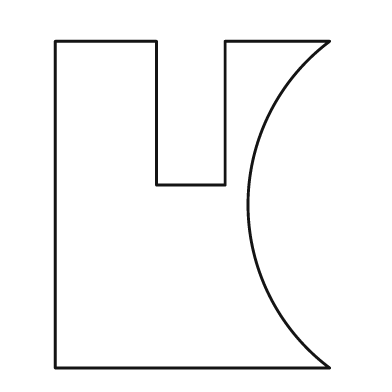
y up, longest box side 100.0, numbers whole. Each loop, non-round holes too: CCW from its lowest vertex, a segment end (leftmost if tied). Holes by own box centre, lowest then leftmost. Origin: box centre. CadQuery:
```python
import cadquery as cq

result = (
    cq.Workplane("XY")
    .moveTo(-42.0, -50.0)
    .lineTo(42.0, -50.0)
    .threePointArc((17.0, 0.0), (42.0, 50.0))
    .lineTo(10.0, 50.0)
    .lineTo(10.0, 6.0)
    .lineTo(-11.0, 6.0)
    .lineTo(-11.0, 50.0)
    .lineTo(-42.0, 50.0)
    .close()
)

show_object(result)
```